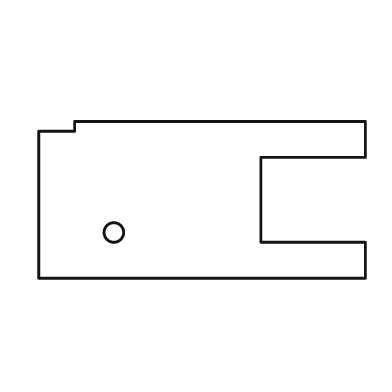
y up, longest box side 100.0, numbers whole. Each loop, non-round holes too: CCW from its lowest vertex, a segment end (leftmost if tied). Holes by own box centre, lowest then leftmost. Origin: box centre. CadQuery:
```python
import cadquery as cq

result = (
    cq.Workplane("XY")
    .moveTo(-50.0, -24.0)
    .lineTo(50.0, -24.0)
    .lineTo(50.0, -13.0)
    .lineTo(18.0, -13.0)
    .lineTo(18.0, 13.0)
    .lineTo(50.0, 13.0)
    .lineTo(50.0, 24.0)
    .lineTo(-39.0, 24.0)
    .lineTo(-39.0, 21.0)
    .lineTo(-50.0, 21.0)
    .close()
    .moveTo(-27.0, -10.0)
    .circle(3.0)
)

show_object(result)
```